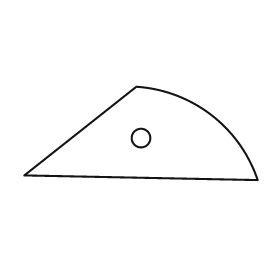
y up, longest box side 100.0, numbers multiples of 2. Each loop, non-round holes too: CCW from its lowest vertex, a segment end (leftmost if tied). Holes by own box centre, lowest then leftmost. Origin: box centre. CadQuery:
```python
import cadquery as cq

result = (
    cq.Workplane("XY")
    .moveTo(50.0, -20.0)
    .threePointArc((30.0, 8.0), (-2.0, 20.0))
    .lineTo(-50.0, -18.0)
    .close()
    .moveTo(0.0, -2.0)
    .circle(4.0)
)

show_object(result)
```